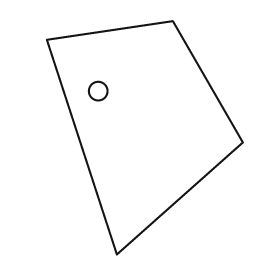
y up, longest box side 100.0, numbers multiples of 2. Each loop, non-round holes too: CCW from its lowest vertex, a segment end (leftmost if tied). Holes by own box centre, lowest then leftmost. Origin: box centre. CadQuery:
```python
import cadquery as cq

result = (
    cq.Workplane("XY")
    .moveTo(-12.0, -50.0)
    .lineTo(42.0, -2.0)
    .lineTo(12.0, 50.0)
    .lineTo(-42.0, 42.0)
    .close()
    .moveTo(-20.0, 20.0)
    .circle(4.0)
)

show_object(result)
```